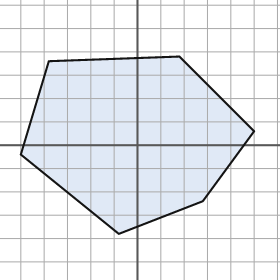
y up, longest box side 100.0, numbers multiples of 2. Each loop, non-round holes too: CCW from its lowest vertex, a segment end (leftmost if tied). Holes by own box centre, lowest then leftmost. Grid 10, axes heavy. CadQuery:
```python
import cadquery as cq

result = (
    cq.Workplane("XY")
    .moveTo(-8.0, -38.0)
    .lineTo(28.0, -24.0)
    .lineTo(50.0, 6.0)
    .lineTo(18.0, 38.0)
    .lineTo(-38.0, 36.0)
    .lineTo(-50.0, -4.0)
    .close()
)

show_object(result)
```